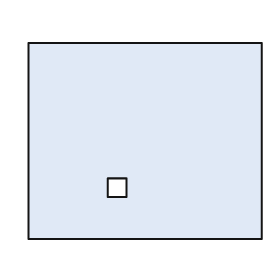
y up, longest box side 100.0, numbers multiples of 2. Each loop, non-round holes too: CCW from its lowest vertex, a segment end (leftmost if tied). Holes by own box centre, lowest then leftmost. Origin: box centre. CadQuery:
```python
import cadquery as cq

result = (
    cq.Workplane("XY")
    .moveTo(-50.0, -42.0)
    .lineTo(50.0, -42.0)
    .lineTo(50.0, 42.0)
    .lineTo(-50.0, 42.0)
    .close()
    .moveTo(-16.0, -24.0)
    .lineTo(-8.0, -24.0)
    .lineTo(-8.0, -16.0)
    .lineTo(-16.0, -16.0)
    .close()
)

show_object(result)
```